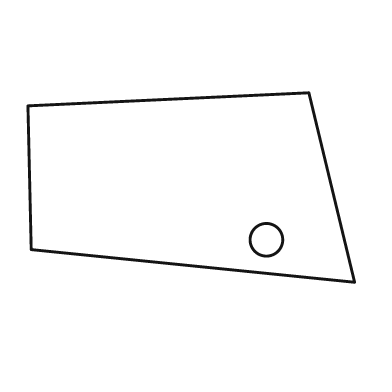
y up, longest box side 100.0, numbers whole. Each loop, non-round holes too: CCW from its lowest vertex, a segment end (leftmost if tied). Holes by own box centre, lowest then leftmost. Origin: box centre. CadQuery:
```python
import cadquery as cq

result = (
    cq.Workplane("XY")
    .moveTo(50.0, -29.0)
    .lineTo(36.0, 29.0)
    .lineTo(-50.0, 25.0)
    .lineTo(-49.0, -19.0)
    .close()
    .moveTo(23.0, -16.0)
    .circle(5.0)
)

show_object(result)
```